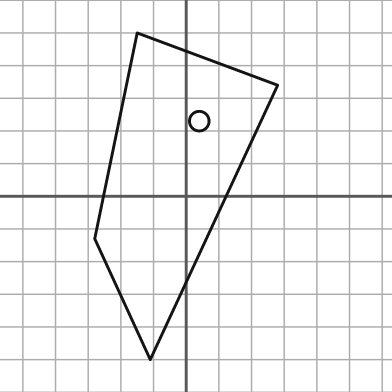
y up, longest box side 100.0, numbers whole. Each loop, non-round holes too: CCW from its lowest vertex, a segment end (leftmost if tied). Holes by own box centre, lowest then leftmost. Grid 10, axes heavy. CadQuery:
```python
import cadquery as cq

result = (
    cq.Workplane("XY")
    .moveTo(-11.0, -50.0)
    .lineTo(28.0, 34.0)
    .lineTo(-15.0, 50.0)
    .lineTo(-28.0, -13.0)
    .close()
    .moveTo(4.0, 23.0)
    .circle(3.0)
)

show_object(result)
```